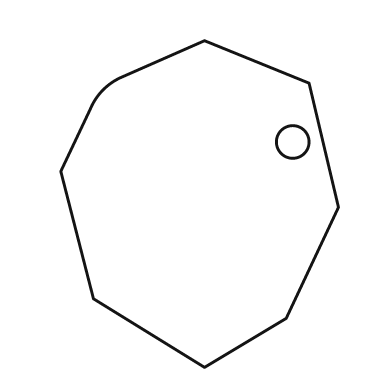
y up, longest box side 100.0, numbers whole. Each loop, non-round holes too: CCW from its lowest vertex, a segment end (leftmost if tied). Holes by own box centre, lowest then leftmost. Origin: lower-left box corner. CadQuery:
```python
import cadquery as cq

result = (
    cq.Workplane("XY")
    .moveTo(44.0, 0.0)
    .lineTo(69.0, 15.0)
    .lineTo(85.0, 49.0)
    .lineTo(76.0, 87.0)
    .lineTo(44.0, 100.0)
    .lineTo(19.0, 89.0)
    .threePointArc((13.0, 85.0), (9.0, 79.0))
    .lineTo(0.0, 60.0)
    .lineTo(10.0, 21.0)
    .close()
    .moveTo(71.0, 69.0)
    .circle(5.0)
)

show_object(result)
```